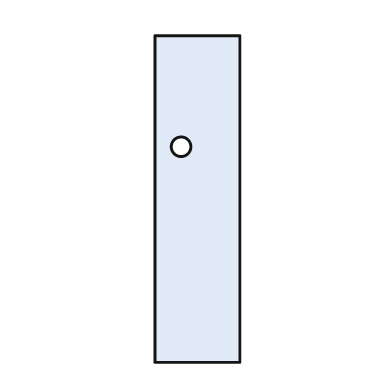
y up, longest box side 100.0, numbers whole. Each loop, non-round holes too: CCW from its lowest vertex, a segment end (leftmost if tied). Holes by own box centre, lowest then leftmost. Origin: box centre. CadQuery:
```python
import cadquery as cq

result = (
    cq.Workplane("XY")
    .moveTo(-13.0, -50.0)
    .lineTo(13.0, -50.0)
    .lineTo(13.0, 50.0)
    .lineTo(-13.0, 50.0)
    .close()
    .moveTo(-5.0, 16.0)
    .circle(3.0)
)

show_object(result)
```